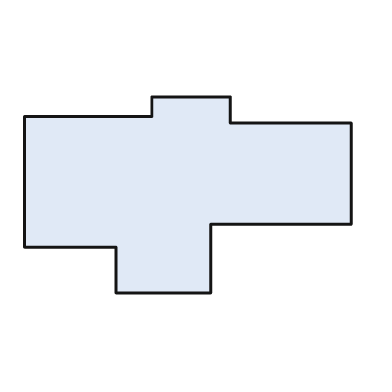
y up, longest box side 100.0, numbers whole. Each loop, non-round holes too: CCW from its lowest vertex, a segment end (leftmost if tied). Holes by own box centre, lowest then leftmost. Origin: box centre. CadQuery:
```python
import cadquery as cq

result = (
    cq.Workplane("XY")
    .moveTo(-22.0, -30.0)
    .lineTo(7.0, -30.0)
    .lineTo(7.0, -9.0)
    .lineTo(50.0, -9.0)
    .lineTo(50.0, 22.0)
    .lineTo(13.0, 22.0)
    .lineTo(13.0, 30.0)
    .lineTo(-11.0, 30.0)
    .lineTo(-11.0, 24.0)
    .lineTo(-50.0, 24.0)
    .lineTo(-50.0, -16.0)
    .lineTo(-22.0, -16.0)
    .close()
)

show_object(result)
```